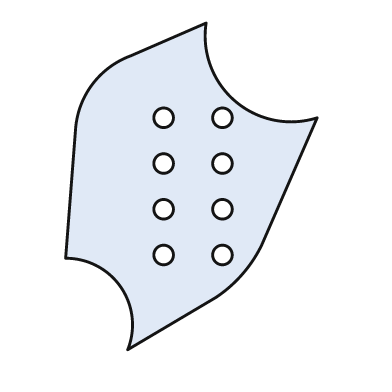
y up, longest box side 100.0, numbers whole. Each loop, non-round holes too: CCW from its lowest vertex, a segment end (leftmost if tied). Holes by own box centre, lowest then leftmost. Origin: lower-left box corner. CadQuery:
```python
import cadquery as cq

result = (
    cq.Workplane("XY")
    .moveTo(19.0, 0.0)
    .lineTo(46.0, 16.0)
    .threePointArc((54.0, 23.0), (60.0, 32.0))
    .lineTo(77.0, 71.0)
    .threePointArc((52.0, 76.0), (43.0, 100.0))
    .lineTo(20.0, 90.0)
    .threePointArc((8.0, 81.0), (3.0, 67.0))
    .lineTo(0.0, 28.0)
    .threePointArc((17.0, 19.0), (19.0, 0.0))
    .close()
    .moveTo(30.0, 29.0)
    .circle(3.0)
    .moveTo(48.0, 29.0)
    .circle(3.0)
    .moveTo(30.0, 43.0)
    .circle(3.0)
    .moveTo(48.0, 43.0)
    .circle(3.0)
    .moveTo(30.0, 57.0)
    .circle(3.0)
    .moveTo(48.0, 57.0)
    .circle(3.0)
    .moveTo(30.0, 71.0)
    .circle(3.0)
    .moveTo(48.0, 71.0)
    .circle(3.0)
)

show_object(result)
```